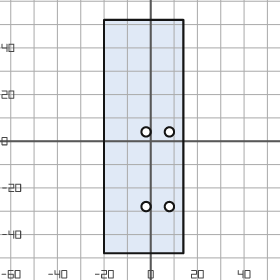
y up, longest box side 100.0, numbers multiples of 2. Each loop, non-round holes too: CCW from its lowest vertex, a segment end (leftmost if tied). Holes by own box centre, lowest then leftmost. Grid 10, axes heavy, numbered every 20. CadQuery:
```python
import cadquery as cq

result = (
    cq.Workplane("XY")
    .moveTo(-20.0, -48.0)
    .lineTo(14.0, -48.0)
    .lineTo(14.0, 52.0)
    .lineTo(-20.0, 52.0)
    .close()
    .moveTo(-2.0, -28.0)
    .circle(2.0)
    .moveTo(8.0, -28.0)
    .circle(2.0)
    .moveTo(-2.0, 4.0)
    .circle(2.0)
    .moveTo(8.0, 4.0)
    .circle(2.0)
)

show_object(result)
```